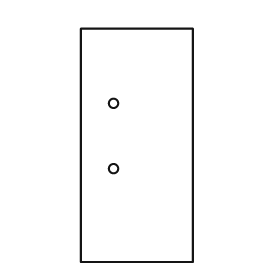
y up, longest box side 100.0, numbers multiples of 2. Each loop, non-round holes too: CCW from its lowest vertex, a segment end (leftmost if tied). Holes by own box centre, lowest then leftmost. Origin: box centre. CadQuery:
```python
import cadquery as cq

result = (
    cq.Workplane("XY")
    .moveTo(-24.0, -50.0)
    .lineTo(24.0, -50.0)
    .lineTo(24.0, 50.0)
    .lineTo(-24.0, 50.0)
    .close()
    .moveTo(-10.0, -10.0)
    .circle(2.0)
    .moveTo(-10.0, 18.0)
    .circle(2.0)
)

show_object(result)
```